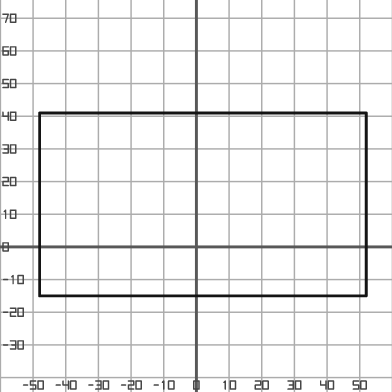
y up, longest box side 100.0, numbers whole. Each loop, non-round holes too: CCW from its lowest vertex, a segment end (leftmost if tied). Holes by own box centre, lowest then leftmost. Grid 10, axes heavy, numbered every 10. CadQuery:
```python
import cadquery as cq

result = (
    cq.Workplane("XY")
    .moveTo(-48.0, -15.0)
    .lineTo(52.0, -15.0)
    .lineTo(52.0, 41.0)
    .lineTo(-48.0, 41.0)
    .close()
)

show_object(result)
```